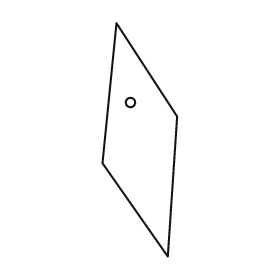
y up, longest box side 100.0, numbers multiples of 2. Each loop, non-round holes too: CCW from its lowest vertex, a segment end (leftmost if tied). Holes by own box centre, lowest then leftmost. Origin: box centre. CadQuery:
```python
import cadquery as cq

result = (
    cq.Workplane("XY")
    .moveTo(12.0, -50.0)
    .lineTo(16.0, 10.0)
    .lineTo(-10.0, 50.0)
    .lineTo(-16.0, -10.0)
    .close()
    .moveTo(-4.0, 16.0)
    .circle(2.0)
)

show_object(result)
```